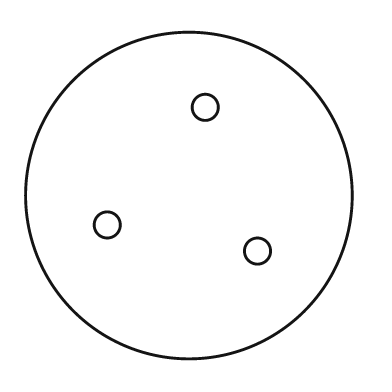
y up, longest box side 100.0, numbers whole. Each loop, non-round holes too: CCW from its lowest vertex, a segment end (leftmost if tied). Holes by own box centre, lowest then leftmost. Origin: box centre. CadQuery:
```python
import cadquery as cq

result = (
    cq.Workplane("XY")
    .moveTo(0.0, 0.0)
    .circle(50.0)
    .moveTo(21.0, -17.0)
    .circle(4.0)
    .moveTo(-25.0, -9.0)
    .circle(4.0)
    .moveTo(5.0, 27.0)
    .circle(4.0)
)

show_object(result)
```